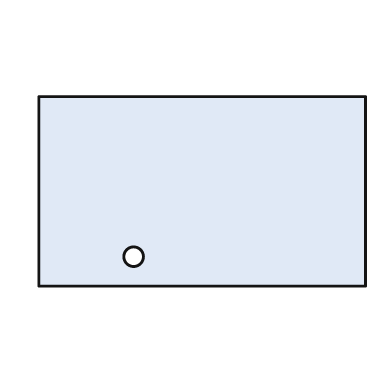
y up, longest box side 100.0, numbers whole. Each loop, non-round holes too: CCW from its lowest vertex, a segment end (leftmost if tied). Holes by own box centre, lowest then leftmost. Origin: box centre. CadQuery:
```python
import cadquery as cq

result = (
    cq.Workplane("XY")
    .moveTo(-50.0, -29.0)
    .lineTo(50.0, -29.0)
    .lineTo(50.0, 29.0)
    .lineTo(-50.0, 29.0)
    .close()
    .moveTo(-21.0, -20.0)
    .circle(3.0)
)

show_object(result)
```